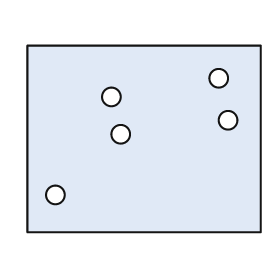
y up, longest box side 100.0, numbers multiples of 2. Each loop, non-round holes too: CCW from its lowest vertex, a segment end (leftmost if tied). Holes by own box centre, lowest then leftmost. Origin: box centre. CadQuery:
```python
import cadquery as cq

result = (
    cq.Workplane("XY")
    .moveTo(-50.0, -40.0)
    .lineTo(50.0, -40.0)
    .lineTo(50.0, 40.0)
    .lineTo(-50.0, 40.0)
    .close()
    .moveTo(-38.0, -24.0)
    .circle(4.0)
    .moveTo(-10.0, 2.0)
    .circle(4.0)
    .moveTo(36.0, 8.0)
    .circle(4.0)
    .moveTo(-14.0, 18.0)
    .circle(4.0)
    .moveTo(32.0, 26.0)
    .circle(4.0)
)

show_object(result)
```